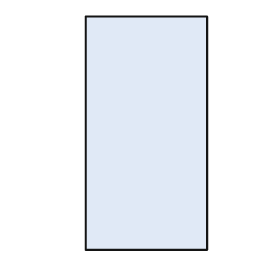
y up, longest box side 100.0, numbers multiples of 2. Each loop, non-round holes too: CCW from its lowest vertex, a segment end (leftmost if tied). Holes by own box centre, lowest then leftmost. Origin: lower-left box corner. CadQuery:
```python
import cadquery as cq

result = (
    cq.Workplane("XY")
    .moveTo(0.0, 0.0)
    .lineTo(52.0, 0.0)
    .lineTo(52.0, 100.0)
    .lineTo(0.0, 100.0)
    .close()
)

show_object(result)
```